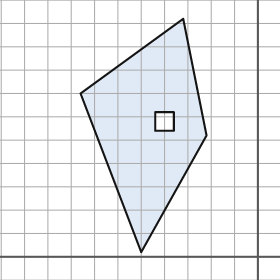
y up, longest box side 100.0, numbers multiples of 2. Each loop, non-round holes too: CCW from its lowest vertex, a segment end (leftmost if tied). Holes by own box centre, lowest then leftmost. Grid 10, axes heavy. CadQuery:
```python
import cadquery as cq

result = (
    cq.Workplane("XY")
    .moveTo(-50.0, 2.0)
    .lineTo(-22.0, 52.0)
    .lineTo(-32.0, 102.0)
    .lineTo(-76.0, 70.0)
    .close()
    .moveTo(-44.0, 54.0)
    .lineTo(-36.0, 54.0)
    .lineTo(-36.0, 62.0)
    .lineTo(-44.0, 62.0)
    .close()
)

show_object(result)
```